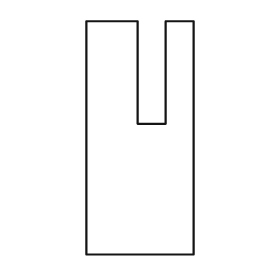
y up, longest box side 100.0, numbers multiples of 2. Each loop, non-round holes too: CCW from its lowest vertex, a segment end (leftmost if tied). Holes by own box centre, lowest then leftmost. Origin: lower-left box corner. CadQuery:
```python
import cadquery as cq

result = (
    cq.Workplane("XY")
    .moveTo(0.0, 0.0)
    .lineTo(46.0, 0.0)
    .lineTo(46.0, 100.0)
    .lineTo(34.0, 100.0)
    .lineTo(34.0, 56.0)
    .lineTo(22.0, 56.0)
    .lineTo(22.0, 100.0)
    .lineTo(0.0, 100.0)
    .close()
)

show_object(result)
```